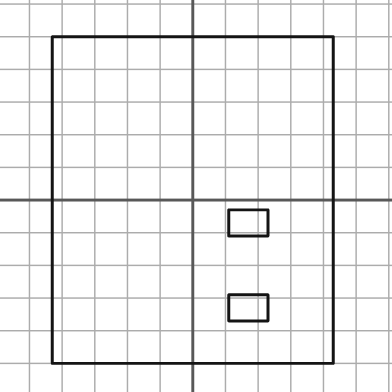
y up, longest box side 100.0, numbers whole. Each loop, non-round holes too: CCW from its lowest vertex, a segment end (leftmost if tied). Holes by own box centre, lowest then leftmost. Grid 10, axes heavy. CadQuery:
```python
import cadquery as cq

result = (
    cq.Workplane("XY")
    .moveTo(-43.0, -50.0)
    .lineTo(43.0, -50.0)
    .lineTo(43.0, 50.0)
    .lineTo(-43.0, 50.0)
    .close()
    .moveTo(11.0, -37.0)
    .lineTo(23.0, -37.0)
    .lineTo(23.0, -29.0)
    .lineTo(11.0, -29.0)
    .close()
    .moveTo(11.0, -11.0)
    .lineTo(23.0, -11.0)
    .lineTo(23.0, -3.0)
    .lineTo(11.0, -3.0)
    .close()
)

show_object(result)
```